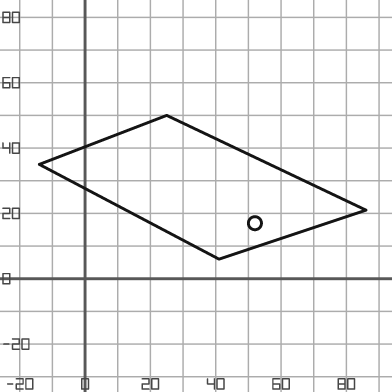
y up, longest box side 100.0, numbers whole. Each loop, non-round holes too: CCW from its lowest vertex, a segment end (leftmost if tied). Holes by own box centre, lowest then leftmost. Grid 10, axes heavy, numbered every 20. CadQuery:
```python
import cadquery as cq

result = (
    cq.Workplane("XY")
    .moveTo(41.0, 6.0)
    .lineTo(86.0, 21.0)
    .lineTo(25.0, 50.0)
    .lineTo(-14.0, 35.0)
    .close()
    .moveTo(52.0, 17.0)
    .circle(2.0)
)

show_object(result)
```